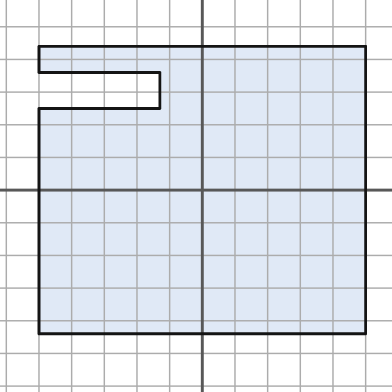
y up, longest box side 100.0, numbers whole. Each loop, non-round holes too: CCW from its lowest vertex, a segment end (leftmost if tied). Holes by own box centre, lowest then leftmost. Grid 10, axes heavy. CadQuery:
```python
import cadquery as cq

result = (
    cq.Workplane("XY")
    .moveTo(-50.0, -44.0)
    .lineTo(50.0, -44.0)
    .lineTo(50.0, 44.0)
    .lineTo(-50.0, 44.0)
    .lineTo(-50.0, 36.0)
    .lineTo(-13.0, 36.0)
    .lineTo(-13.0, 25.0)
    .lineTo(-50.0, 25.0)
    .close()
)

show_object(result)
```